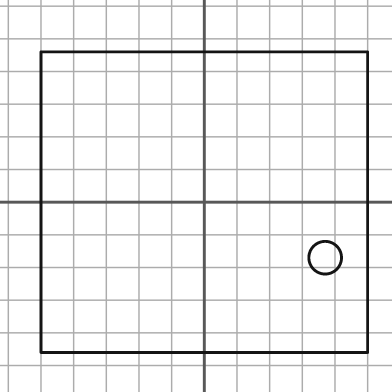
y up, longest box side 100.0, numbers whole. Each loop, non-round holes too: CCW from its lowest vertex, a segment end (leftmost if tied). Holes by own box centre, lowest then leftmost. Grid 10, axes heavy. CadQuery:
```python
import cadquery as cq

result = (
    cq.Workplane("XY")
    .moveTo(-50.0, -46.0)
    .lineTo(50.0, -46.0)
    .lineTo(50.0, 46.0)
    .lineTo(-50.0, 46.0)
    .close()
    .moveTo(37.0, -17.0)
    .circle(5.0)
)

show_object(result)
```